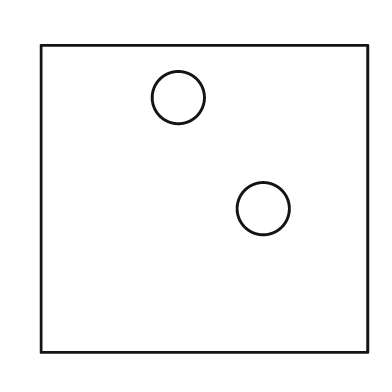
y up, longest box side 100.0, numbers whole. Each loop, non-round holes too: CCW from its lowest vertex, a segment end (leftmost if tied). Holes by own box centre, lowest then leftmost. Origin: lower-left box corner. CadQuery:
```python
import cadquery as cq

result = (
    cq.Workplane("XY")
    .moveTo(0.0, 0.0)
    .lineTo(100.0, 0.0)
    .lineTo(100.0, 94.0)
    .lineTo(0.0, 94.0)
    .close()
    .moveTo(68.0, 44.0)
    .circle(8.0)
    .moveTo(42.0, 78.0)
    .circle(8.0)
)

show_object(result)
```